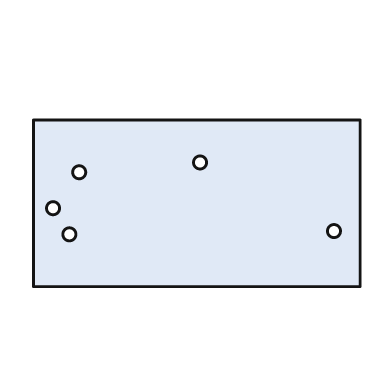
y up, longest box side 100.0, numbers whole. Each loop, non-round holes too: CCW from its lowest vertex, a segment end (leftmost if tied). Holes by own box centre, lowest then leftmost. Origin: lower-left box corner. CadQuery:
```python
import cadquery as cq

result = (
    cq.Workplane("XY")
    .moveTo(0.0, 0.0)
    .lineTo(100.0, 0.0)
    .lineTo(100.0, 51.0)
    .lineTo(0.0, 51.0)
    .close()
    .moveTo(11.0, 16.0)
    .circle(2.0)
    .moveTo(92.0, 17.0)
    .circle(2.0)
    .moveTo(6.0, 24.0)
    .circle(2.0)
    .moveTo(14.0, 35.0)
    .circle(2.0)
    .moveTo(51.0, 38.0)
    .circle(2.0)
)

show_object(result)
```